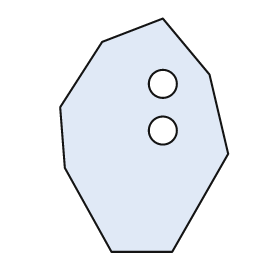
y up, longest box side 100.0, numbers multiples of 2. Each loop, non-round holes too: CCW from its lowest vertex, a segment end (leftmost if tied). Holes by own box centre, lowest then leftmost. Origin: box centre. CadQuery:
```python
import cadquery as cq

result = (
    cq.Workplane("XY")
    .moveTo(-14.0, -50.0)
    .lineTo(12.0, -50.0)
    .lineTo(36.0, -8.0)
    .lineTo(28.0, 26.0)
    .lineTo(8.0, 50.0)
    .lineTo(-18.0, 40.0)
    .lineTo(-36.0, 12.0)
    .lineTo(-34.0, -14.0)
    .close()
    .moveTo(8.0, 2.0)
    .circle(6.0)
    .moveTo(8.0, 22.0)
    .circle(6.0)
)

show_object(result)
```